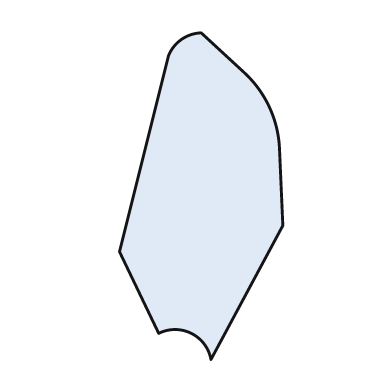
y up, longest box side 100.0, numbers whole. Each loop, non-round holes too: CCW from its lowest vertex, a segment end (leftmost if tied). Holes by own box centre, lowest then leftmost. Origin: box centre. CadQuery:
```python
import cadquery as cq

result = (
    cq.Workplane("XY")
    .moveTo(3.0, -50.0)
    .lineTo(25.0, -9.0)
    .lineTo(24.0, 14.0)
    .threePointArc((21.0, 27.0), (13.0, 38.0))
    .lineTo(0.0, 50.0)
    .threePointArc((-6.0, 48.0), (-10.0, 43.0))
    .lineTo(-25.0, -17.0)
    .lineTo(-13.0, -42.0)
    .threePointArc((-3.0, -42.0), (3.0, -50.0))
    .close()
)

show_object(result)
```